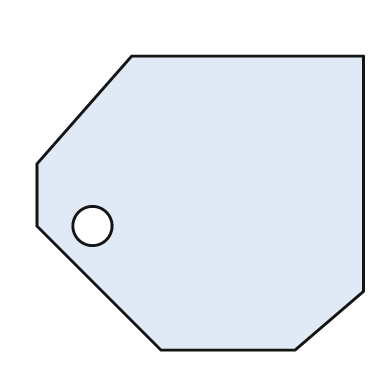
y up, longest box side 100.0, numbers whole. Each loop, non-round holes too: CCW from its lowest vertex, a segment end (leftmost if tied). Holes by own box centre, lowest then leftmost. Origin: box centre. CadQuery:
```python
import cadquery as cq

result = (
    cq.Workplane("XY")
    .moveTo(-12.0, -45.0)
    .lineTo(29.0, -45.0)
    .lineTo(50.0, -27.0)
    .lineTo(50.0, 45.0)
    .lineTo(-21.0, 45.0)
    .lineTo(-50.0, 12.0)
    .lineTo(-50.0, -7.0)
    .close()
    .moveTo(-33.0, -7.0)
    .circle(6.0)
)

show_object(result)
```